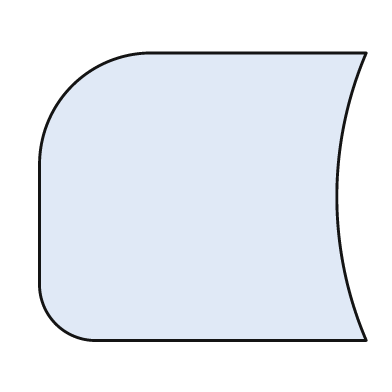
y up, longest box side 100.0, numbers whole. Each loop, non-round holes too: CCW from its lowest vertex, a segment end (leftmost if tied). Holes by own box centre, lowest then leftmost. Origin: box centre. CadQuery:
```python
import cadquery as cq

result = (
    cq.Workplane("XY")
    .moveTo(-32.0, -44.0)
    .lineTo(50.0, -44.0)
    .threePointArc((41.0, 0.0), (50.0, 44.0))
    .lineTo(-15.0, 44.0)
    .threePointArc((-40.0, 34.0), (-50.0, 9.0))
    .lineTo(-50.0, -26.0)
    .threePointArc((-45.0, -39.0), (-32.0, -44.0))
    .close()
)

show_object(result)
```